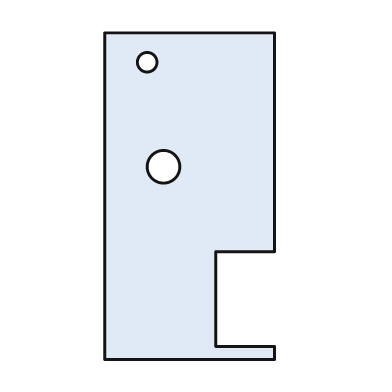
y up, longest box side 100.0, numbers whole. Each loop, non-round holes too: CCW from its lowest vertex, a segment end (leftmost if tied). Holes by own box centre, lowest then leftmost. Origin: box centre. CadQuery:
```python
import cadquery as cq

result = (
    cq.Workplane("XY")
    .moveTo(-26.0, -50.0)
    .lineTo(26.0, -50.0)
    .lineTo(26.0, -46.0)
    .lineTo(8.0, -46.0)
    .lineTo(8.0, -17.0)
    .lineTo(26.0, -17.0)
    .lineTo(26.0, 50.0)
    .lineTo(-26.0, 50.0)
    .close()
    .moveTo(-8.0, 9.0)
    .circle(5.0)
    .moveTo(-13.0, 41.0)
    .circle(3.0)
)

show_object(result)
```